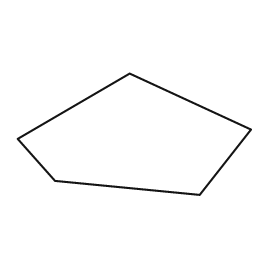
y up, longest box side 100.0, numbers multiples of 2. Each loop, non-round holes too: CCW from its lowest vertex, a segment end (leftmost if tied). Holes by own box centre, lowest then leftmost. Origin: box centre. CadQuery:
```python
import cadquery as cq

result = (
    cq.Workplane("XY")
    .moveTo(28.0, -26.0)
    .lineTo(50.0, 2.0)
    .lineTo(-2.0, 26.0)
    .lineTo(-50.0, -2.0)
    .lineTo(-34.0, -20.0)
    .close()
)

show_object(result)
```